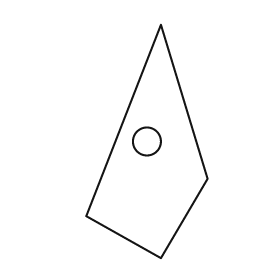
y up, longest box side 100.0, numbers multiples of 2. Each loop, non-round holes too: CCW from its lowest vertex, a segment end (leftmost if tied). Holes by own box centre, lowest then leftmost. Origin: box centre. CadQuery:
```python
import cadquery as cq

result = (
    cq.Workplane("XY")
    .moveTo(6.0, -50.0)
    .lineTo(26.0, -16.0)
    .lineTo(6.0, 50.0)
    .lineTo(-26.0, -32.0)
    .close()
    .moveTo(0.0, 0.0)
    .circle(6.0)
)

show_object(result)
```